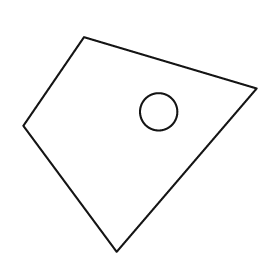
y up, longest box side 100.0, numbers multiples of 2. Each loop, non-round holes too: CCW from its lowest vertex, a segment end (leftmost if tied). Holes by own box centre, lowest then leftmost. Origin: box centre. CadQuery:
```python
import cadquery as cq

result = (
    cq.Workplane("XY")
    .moveTo(-10.0, -46.0)
    .lineTo(50.0, 24.0)
    .lineTo(-24.0, 46.0)
    .lineTo(-50.0, 8.0)
    .close()
    .moveTo(8.0, 14.0)
    .circle(8.0)
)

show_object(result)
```